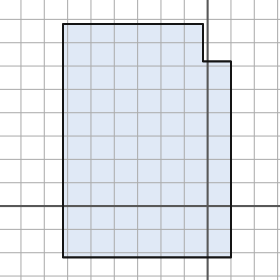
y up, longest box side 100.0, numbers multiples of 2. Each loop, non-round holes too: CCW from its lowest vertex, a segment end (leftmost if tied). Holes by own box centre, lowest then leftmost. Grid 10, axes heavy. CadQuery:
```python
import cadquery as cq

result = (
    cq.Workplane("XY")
    .moveTo(-62.0, -22.0)
    .lineTo(10.0, -22.0)
    .lineTo(10.0, 62.0)
    .lineTo(-2.0, 62.0)
    .lineTo(-2.0, 78.0)
    .lineTo(-62.0, 78.0)
    .close()
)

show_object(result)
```